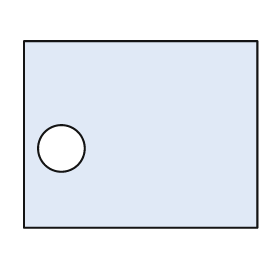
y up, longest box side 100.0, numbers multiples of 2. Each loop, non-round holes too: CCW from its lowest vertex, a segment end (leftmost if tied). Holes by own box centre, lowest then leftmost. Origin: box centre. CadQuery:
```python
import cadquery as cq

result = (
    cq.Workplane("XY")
    .moveTo(-50.0, -40.0)
    .lineTo(50.0, -40.0)
    .lineTo(50.0, 40.0)
    .lineTo(-50.0, 40.0)
    .close()
    .moveTo(-34.0, -6.0)
    .circle(10.0)
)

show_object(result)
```